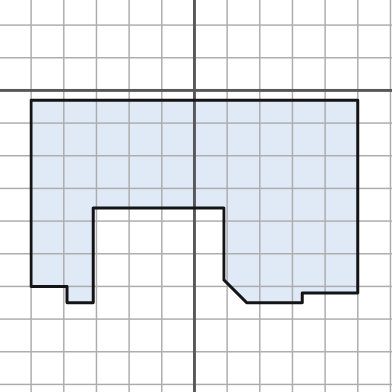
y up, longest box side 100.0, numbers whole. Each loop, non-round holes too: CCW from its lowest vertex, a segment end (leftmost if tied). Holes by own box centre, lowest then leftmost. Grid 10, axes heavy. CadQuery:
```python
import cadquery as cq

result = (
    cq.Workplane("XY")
    .moveTo(-39.0, -65.0)
    .lineTo(-31.0, -65.0)
    .lineTo(-31.0, -36.0)
    .lineTo(9.0, -36.0)
    .lineTo(9.0, -58.0)
    .lineTo(16.0, -65.0)
    .lineTo(33.0, -65.0)
    .lineTo(33.0, -62.0)
    .lineTo(50.0, -62.0)
    .lineTo(50.0, -3.0)
    .lineTo(-50.0, -3.0)
    .lineTo(-50.0, -60.0)
    .lineTo(-39.0, -60.0)
    .close()
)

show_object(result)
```